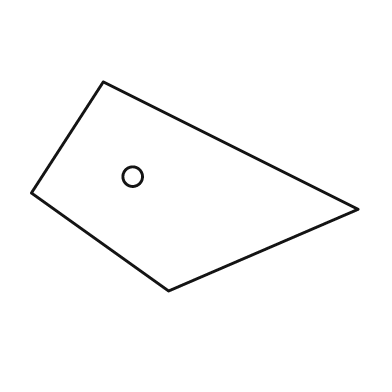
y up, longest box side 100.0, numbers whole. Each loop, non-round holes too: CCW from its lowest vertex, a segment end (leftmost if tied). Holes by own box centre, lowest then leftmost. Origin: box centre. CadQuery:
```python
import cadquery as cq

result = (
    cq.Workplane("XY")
    .moveTo(-8.0, -32.0)
    .lineTo(50.0, -7.0)
    .lineTo(-28.0, 32.0)
    .lineTo(-50.0, -2.0)
    .close()
    .moveTo(-19.0, 3.0)
    .circle(3.0)
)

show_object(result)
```